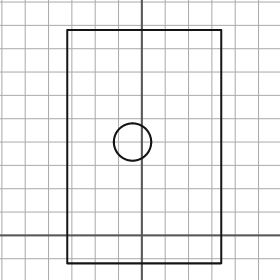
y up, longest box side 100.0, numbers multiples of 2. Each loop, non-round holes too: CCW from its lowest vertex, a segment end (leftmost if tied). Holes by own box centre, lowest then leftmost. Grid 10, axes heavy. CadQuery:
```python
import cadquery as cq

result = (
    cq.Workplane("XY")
    .moveTo(-32.0, -12.0)
    .lineTo(34.0, -12.0)
    .lineTo(34.0, 88.0)
    .lineTo(-32.0, 88.0)
    .close()
    .moveTo(-4.0, 40.0)
    .circle(8.0)
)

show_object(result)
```